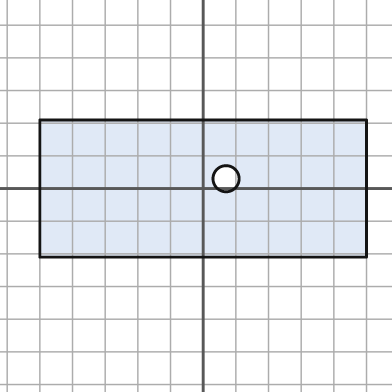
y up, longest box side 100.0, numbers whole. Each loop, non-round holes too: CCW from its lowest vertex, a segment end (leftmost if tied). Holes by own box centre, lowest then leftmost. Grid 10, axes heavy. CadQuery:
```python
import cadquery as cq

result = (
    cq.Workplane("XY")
    .moveTo(-50.0, -21.0)
    .lineTo(50.0, -21.0)
    .lineTo(50.0, 21.0)
    .lineTo(-50.0, 21.0)
    .close()
    .moveTo(7.0, 3.0)
    .circle(4.0)
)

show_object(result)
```